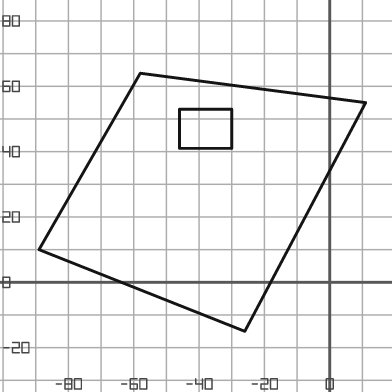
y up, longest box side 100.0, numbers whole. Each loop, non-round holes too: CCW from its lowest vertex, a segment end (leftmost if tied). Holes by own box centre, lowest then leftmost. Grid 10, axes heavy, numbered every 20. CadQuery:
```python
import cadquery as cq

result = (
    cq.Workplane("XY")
    .moveTo(-26.0, -15.0)
    .lineTo(11.0, 55.0)
    .lineTo(-58.0, 64.0)
    .lineTo(-89.0, 10.0)
    .close()
    .moveTo(-46.0, 41.0)
    .lineTo(-30.0, 41.0)
    .lineTo(-30.0, 53.0)
    .lineTo(-46.0, 53.0)
    .close()
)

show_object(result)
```